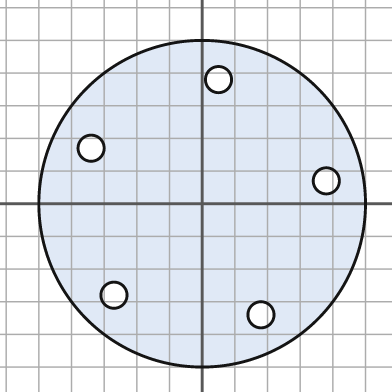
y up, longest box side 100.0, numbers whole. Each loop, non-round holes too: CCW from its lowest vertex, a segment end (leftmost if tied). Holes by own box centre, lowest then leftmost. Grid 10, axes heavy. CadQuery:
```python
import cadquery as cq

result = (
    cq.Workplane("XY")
    .moveTo(0.0, 0.0)
    .circle(50.0)
    .moveTo(18.0, -34.0)
    .circle(4.0)
    .moveTo(-27.0, -28.0)
    .circle(4.0)
    .moveTo(38.0, 7.0)
    .circle(4.0)
    .moveTo(-34.0, 17.0)
    .circle(4.0)
    .moveTo(5.0, 38.0)
    .circle(4.0)
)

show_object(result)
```